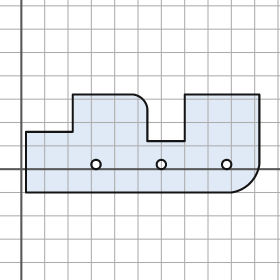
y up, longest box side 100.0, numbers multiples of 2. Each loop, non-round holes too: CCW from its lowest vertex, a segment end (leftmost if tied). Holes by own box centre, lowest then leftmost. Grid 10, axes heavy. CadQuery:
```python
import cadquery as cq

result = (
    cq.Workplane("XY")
    .moveTo(2.0, -10.0)
    .lineTo(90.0, -10.0)
    .threePointArc((98.0, -6.0), (102.0, 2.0))
    .lineTo(102.0, 32.0)
    .lineTo(70.0, 32.0)
    .lineTo(70.0, 12.0)
    .lineTo(54.0, 12.0)
    .lineTo(54.0, 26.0)
    .threePointArc((52.0, 30.0), (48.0, 32.0))
    .lineTo(22.0, 32.0)
    .lineTo(22.0, 16.0)
    .lineTo(2.0, 16.0)
    .close()
    .moveTo(32.0, 2.0)
    .circle(2.0)
    .moveTo(60.0, 2.0)
    .circle(2.0)
    .moveTo(88.0, 2.0)
    .circle(2.0)
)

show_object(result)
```